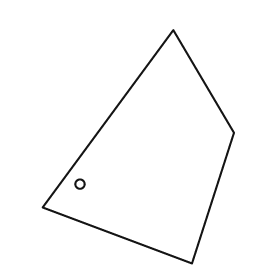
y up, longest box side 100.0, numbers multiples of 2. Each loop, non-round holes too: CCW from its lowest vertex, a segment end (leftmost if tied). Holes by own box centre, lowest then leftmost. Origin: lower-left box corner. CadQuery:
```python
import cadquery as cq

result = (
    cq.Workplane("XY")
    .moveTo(64.0, 0.0)
    .lineTo(82.0, 56.0)
    .lineTo(56.0, 100.0)
    .lineTo(0.0, 24.0)
    .close()
    .moveTo(16.0, 34.0)
    .circle(2.0)
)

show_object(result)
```